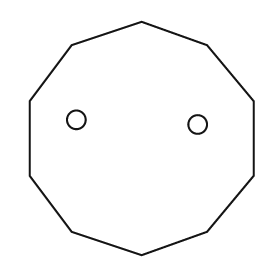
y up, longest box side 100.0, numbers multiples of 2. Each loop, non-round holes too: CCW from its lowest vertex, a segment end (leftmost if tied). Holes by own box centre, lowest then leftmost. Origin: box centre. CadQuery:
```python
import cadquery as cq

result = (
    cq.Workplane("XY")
    .moveTo(0.0, -50.0)
    .lineTo(28.0, -40.0)
    .lineTo(48.0, -16.0)
    .lineTo(48.0, 16.0)
    .lineTo(28.0, 40.0)
    .lineTo(0.0, 50.0)
    .lineTo(-30.0, 40.0)
    .lineTo(-48.0, 16.0)
    .lineTo(-48.0, -16.0)
    .lineTo(-30.0, -40.0)
    .close()
    .moveTo(24.0, 6.0)
    .circle(4.0)
    .moveTo(-28.0, 8.0)
    .circle(4.0)
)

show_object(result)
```